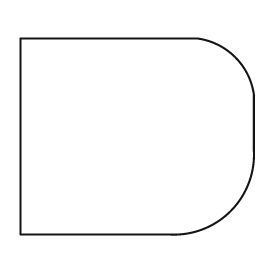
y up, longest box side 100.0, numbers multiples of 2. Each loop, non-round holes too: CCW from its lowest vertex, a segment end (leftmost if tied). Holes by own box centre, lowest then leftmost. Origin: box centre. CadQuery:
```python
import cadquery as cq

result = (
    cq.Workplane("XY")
    .moveTo(-50.0, -42.0)
    .lineTo(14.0, -42.0)
    .threePointArc((40.0, -32.0), (50.0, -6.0))
    .lineTo(50.0, 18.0)
    .threePointArc((42.0, 34.0), (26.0, 42.0))
    .lineTo(-50.0, 42.0)
    .close()
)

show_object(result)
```